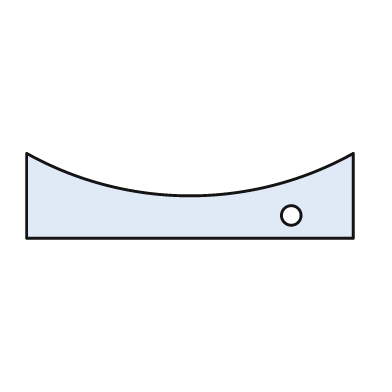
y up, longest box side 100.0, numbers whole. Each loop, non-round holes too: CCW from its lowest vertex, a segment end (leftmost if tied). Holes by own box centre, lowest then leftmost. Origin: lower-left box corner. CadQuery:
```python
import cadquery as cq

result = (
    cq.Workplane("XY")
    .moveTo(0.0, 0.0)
    .lineTo(100.0, 0.0)
    .lineTo(100.0, 26.0)
    .threePointArc((50.0, 13.0), (0.0, 26.0))
    .close()
    .moveTo(81.0, 7.0)
    .circle(3.0)
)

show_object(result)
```